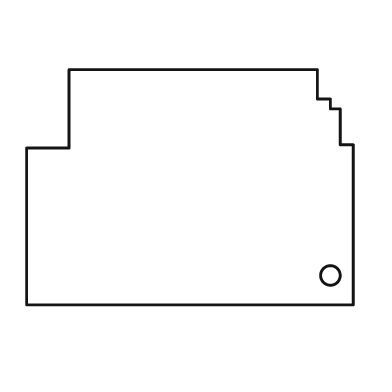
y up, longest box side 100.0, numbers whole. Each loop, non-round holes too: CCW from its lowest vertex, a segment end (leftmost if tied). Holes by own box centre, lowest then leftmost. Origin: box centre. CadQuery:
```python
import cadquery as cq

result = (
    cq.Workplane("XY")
    .moveTo(-50.0, -36.0)
    .lineTo(50.0, -36.0)
    .lineTo(50.0, 13.0)
    .lineTo(46.0, 13.0)
    .lineTo(46.0, 24.0)
    .lineTo(43.0, 24.0)
    .lineTo(43.0, 27.0)
    .lineTo(39.0, 27.0)
    .lineTo(39.0, 36.0)
    .lineTo(-37.0, 36.0)
    .lineTo(-37.0, 12.0)
    .lineTo(-50.0, 12.0)
    .close()
    .moveTo(43.0, -27.0)
    .circle(3.0)
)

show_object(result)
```